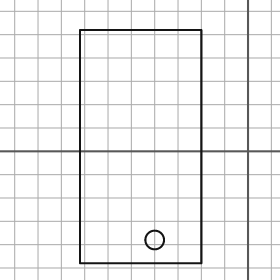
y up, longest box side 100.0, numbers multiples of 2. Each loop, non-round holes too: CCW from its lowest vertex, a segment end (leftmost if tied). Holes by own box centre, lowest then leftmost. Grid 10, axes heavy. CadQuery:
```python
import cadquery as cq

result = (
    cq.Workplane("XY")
    .moveTo(-72.0, -48.0)
    .lineTo(-20.0, -48.0)
    .lineTo(-20.0, 52.0)
    .lineTo(-72.0, 52.0)
    .close()
    .moveTo(-40.0, -38.0)
    .circle(4.0)
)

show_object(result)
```